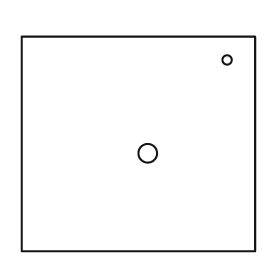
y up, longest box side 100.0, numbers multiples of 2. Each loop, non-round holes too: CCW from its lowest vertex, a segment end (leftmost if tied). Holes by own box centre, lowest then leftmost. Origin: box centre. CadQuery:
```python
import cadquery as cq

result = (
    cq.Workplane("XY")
    .moveTo(-50.0, -46.0)
    .lineTo(50.0, -46.0)
    .lineTo(50.0, 46.0)
    .lineTo(-50.0, 46.0)
    .close()
    .moveTo(4.0, -4.0)
    .circle(4.0)
    .moveTo(38.0, 36.0)
    .circle(2.0)
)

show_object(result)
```